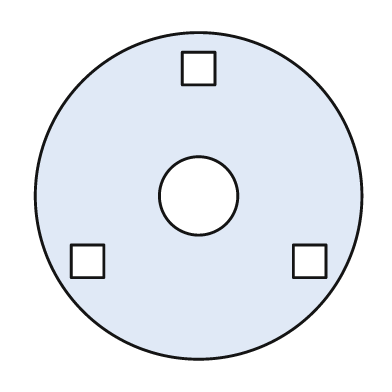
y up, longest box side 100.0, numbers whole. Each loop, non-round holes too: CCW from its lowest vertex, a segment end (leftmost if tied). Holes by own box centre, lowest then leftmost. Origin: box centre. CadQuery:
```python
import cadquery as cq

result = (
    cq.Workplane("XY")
    .moveTo(0.0, 0.0)
    .circle(50.0)
    .moveTo(-39.0, -25.0)
    .lineTo(-29.0, -25.0)
    .lineTo(-29.0, -15.0)
    .lineTo(-39.0, -15.0)
    .close()
    .moveTo(29.0, -25.0)
    .lineTo(39.0, -25.0)
    .lineTo(39.0, -15.0)
    .lineTo(29.0, -15.0)
    .close()
    .moveTo(0.0, 0.0)
    .circle(12.0)
    .moveTo(-5.0, 34.0)
    .lineTo(5.0, 34.0)
    .lineTo(5.0, 44.0)
    .lineTo(-5.0, 44.0)
    .close()
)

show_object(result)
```